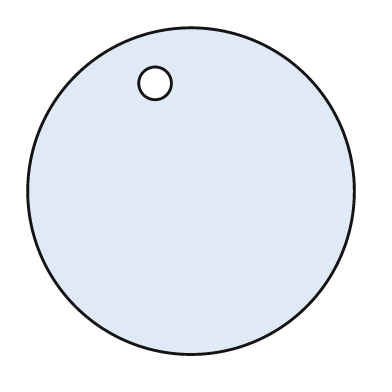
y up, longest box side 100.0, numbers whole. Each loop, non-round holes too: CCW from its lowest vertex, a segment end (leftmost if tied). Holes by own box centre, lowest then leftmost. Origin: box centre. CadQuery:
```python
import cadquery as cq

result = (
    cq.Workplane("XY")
    .moveTo(0.0, 0.0)
    .circle(50.0)
    .moveTo(-11.0, 33.0)
    .circle(5.0)
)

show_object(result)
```